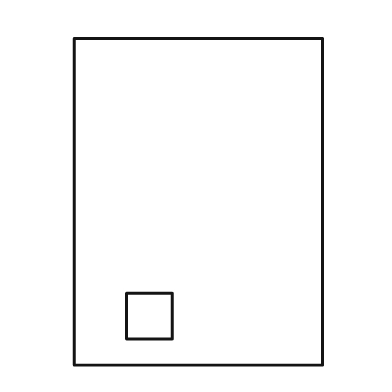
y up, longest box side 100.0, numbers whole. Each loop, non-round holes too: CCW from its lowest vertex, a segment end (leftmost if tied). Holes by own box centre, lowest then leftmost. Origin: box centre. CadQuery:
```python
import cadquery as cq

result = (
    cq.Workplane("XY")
    .moveTo(-38.0, -50.0)
    .lineTo(38.0, -50.0)
    .lineTo(38.0, 50.0)
    .lineTo(-38.0, 50.0)
    .close()
    .moveTo(-22.0, -42.0)
    .lineTo(-8.0, -42.0)
    .lineTo(-8.0, -28.0)
    .lineTo(-22.0, -28.0)
    .close()
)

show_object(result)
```